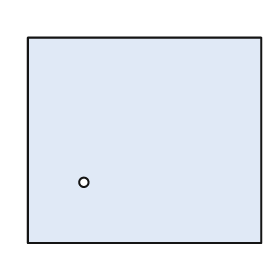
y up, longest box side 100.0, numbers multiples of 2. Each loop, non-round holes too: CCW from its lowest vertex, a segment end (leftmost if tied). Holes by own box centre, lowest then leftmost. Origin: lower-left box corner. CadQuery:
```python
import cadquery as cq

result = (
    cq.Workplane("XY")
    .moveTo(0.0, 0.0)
    .lineTo(100.0, 0.0)
    .lineTo(100.0, 88.0)
    .lineTo(0.0, 88.0)
    .close()
    .moveTo(24.0, 26.0)
    .circle(2.0)
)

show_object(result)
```